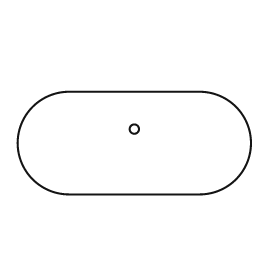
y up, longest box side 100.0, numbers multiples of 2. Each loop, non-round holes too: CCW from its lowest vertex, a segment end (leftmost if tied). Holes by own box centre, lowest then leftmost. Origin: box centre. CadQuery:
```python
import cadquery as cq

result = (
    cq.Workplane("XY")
    .moveTo(-28.0, -22.0)
    .lineTo(28.0, -22.0)
    .threePointArc((50.0, 0.0), (28.0, 22.0))
    .lineTo(-28.0, 22.0)
    .threePointArc((-50.0, 0.0), (-28.0, -22.0))
    .close()
    .moveTo(0.0, 6.0)
    .circle(2.0)
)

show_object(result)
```